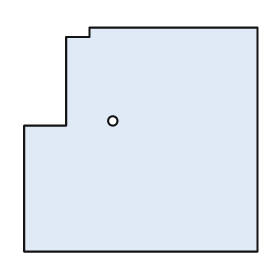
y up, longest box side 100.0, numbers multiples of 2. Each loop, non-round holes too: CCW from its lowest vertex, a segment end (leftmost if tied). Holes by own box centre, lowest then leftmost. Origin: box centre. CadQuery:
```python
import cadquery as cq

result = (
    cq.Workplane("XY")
    .moveTo(-50.0, -48.0)
    .lineTo(50.0, -48.0)
    .lineTo(50.0, 48.0)
    .lineTo(-22.0, 48.0)
    .lineTo(-22.0, 44.0)
    .lineTo(-32.0, 44.0)
    .lineTo(-32.0, 6.0)
    .lineTo(-50.0, 6.0)
    .close()
    .moveTo(-12.0, 8.0)
    .circle(2.0)
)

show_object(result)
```